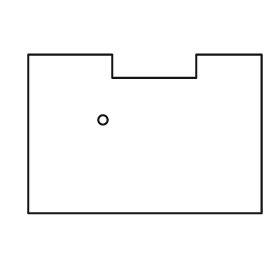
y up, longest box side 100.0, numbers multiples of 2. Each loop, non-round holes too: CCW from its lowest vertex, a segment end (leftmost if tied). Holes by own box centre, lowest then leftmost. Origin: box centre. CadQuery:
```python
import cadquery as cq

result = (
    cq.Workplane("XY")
    .moveTo(-50.0, -34.0)
    .lineTo(50.0, -34.0)
    .lineTo(50.0, 34.0)
    .lineTo(22.0, 34.0)
    .lineTo(22.0, 24.0)
    .lineTo(-14.0, 24.0)
    .lineTo(-14.0, 34.0)
    .lineTo(-50.0, 34.0)
    .close()
    .moveTo(-18.0, 6.0)
    .circle(2.0)
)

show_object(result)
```